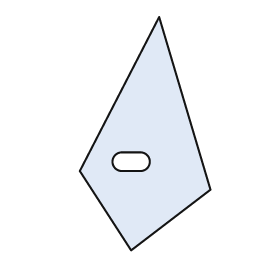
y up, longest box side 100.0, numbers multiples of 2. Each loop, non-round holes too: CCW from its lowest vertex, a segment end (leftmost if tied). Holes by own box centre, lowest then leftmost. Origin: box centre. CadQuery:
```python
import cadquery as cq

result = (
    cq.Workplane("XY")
    .moveTo(-6.0, -50.0)
    .lineTo(28.0, -24.0)
    .lineTo(6.0, 50.0)
    .lineTo(-28.0, -16.0)
    .close()
    .moveTo(-10.0, -16.0)
    .lineTo(-2.0, -16.0)
    .threePointArc((2.0, -12.0), (-2.0, -8.0))
    .lineTo(-10.0, -8.0)
    .threePointArc((-14.0, -12.0), (-10.0, -16.0))
    .close()
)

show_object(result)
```